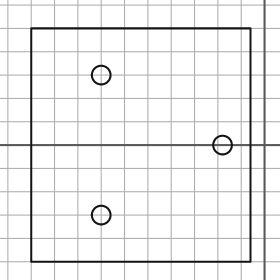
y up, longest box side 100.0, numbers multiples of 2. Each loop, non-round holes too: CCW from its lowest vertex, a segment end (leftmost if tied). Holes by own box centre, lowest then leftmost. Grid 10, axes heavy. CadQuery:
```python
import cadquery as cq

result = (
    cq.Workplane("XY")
    .moveTo(-100.0, -50.0)
    .lineTo(-6.0, -50.0)
    .lineTo(-6.0, 50.0)
    .lineTo(-100.0, 50.0)
    .close()
    .moveTo(-70.0, -30.0)
    .circle(4.0)
    .moveTo(-18.0, 0.0)
    .circle(4.0)
    .moveTo(-70.0, 30.0)
    .circle(4.0)
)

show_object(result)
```